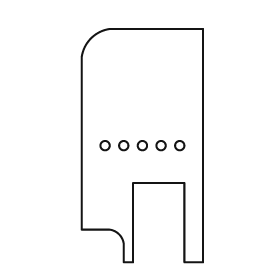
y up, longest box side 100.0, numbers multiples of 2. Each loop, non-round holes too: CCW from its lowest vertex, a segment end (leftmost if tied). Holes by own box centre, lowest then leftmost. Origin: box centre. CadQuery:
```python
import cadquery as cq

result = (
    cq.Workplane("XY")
    .moveTo(-8.0, -50.0)
    .lineTo(-4.0, -50.0)
    .lineTo(-4.0, -16.0)
    .lineTo(18.0, -16.0)
    .lineTo(18.0, -50.0)
    .lineTo(26.0, -50.0)
    .lineTo(26.0, 50.0)
    .lineTo(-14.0, 50.0)
    .threePointArc((-22.0, 46.0), (-26.0, 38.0))
    .lineTo(-26.0, -36.0)
    .lineTo(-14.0, -36.0)
    .threePointArc((-10.0, -38.0), (-8.0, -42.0))
    .close()
    .moveTo(-16.0, 0.0)
    .circle(2.0)
    .moveTo(-8.0, 0.0)
    .circle(2.0)
    .moveTo(0.0, 0.0)
    .circle(2.0)
    .moveTo(8.0, 0.0)
    .circle(2.0)
    .moveTo(16.0, 0.0)
    .circle(2.0)
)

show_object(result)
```